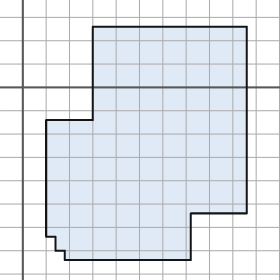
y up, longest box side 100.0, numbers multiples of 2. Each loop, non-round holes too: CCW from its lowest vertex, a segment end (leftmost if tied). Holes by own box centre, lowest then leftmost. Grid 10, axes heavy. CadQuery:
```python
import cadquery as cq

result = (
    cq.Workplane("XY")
    .moveTo(18.0, -74.0)
    .lineTo(72.0, -74.0)
    .lineTo(72.0, -54.0)
    .lineTo(96.0, -54.0)
    .lineTo(96.0, 26.0)
    .lineTo(30.0, 26.0)
    .lineTo(30.0, -14.0)
    .lineTo(10.0, -14.0)
    .lineTo(10.0, -64.0)
    .lineTo(14.0, -64.0)
    .lineTo(14.0, -70.0)
    .lineTo(18.0, -70.0)
    .close()
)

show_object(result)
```